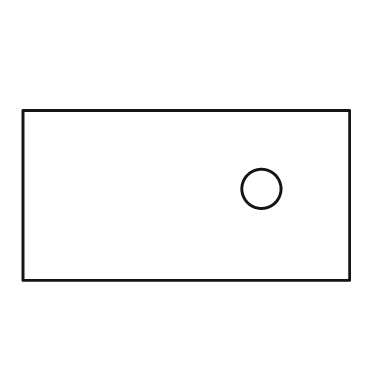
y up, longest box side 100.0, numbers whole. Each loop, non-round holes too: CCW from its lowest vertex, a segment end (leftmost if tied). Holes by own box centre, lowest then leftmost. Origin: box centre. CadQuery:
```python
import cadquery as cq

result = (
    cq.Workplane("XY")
    .moveTo(-50.0, -26.0)
    .lineTo(50.0, -26.0)
    .lineTo(50.0, 26.0)
    .lineTo(-50.0, 26.0)
    .close()
    .moveTo(23.0, 2.0)
    .circle(6.0)
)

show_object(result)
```